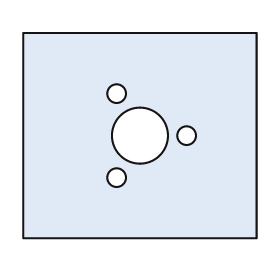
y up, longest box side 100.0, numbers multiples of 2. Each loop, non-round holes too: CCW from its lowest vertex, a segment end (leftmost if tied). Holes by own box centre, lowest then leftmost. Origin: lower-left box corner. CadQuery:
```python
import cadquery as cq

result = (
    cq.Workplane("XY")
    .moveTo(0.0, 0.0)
    .lineTo(100.0, 0.0)
    .lineTo(100.0, 88.0)
    .lineTo(0.0, 88.0)
    .close()
    .moveTo(40.0, 26.0)
    .circle(4.0)
    .moveTo(50.0, 44.0)
    .circle(12.0)
    .moveTo(70.0, 44.0)
    .circle(4.0)
    .moveTo(40.0, 62.0)
    .circle(4.0)
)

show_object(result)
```